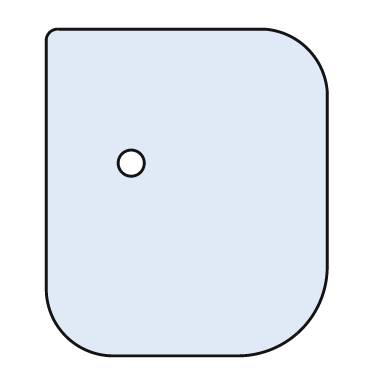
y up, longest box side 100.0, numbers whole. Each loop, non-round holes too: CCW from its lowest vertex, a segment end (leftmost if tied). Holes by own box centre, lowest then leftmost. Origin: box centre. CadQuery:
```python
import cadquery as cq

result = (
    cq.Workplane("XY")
    .moveTo(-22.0, -50.0)
    .lineTo(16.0, -50.0)
    .threePointArc((35.0, -42.0), (43.0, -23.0))
    .lineTo(43.0, 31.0)
    .threePointArc((37.0, 44.0), (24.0, 50.0))
    .lineTo(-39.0, 50.0)
    .threePointArc((-42.0, 49.0), (-43.0, 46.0))
    .lineTo(-43.0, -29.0)
    .threePointArc((-37.0, -44.0), (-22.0, -50.0))
    .close()
    .moveTo(-17.0, 9.0)
    .circle(4.0)
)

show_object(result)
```